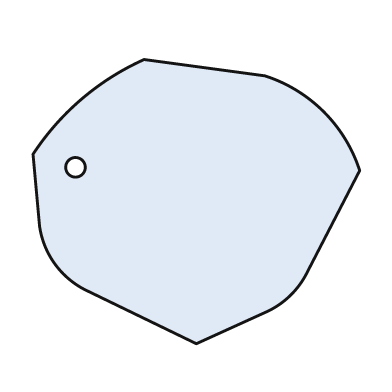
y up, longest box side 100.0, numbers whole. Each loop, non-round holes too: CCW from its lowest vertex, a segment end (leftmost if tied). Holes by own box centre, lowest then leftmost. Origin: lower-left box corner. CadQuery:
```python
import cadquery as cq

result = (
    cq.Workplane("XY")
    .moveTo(50.0, 0.0)
    .lineTo(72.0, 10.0)
    .threePointArc((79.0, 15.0), (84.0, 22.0))
    .lineTo(100.0, 53.0)
    .threePointArc((89.0, 71.0), (71.0, 82.0))
    .lineTo(34.0, 87.0)
    .threePointArc((15.0, 75.0), (0.0, 58.0))
    .lineTo(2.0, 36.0)
    .threePointArc((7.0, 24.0), (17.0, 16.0))
    .close()
    .moveTo(13.0, 54.0)
    .circle(3.0)
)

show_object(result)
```